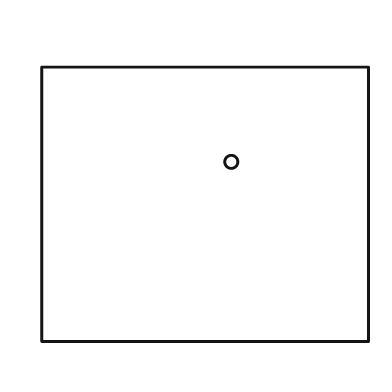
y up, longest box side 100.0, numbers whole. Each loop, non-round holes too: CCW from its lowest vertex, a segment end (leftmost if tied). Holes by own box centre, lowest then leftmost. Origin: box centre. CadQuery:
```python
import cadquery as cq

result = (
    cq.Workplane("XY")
    .moveTo(-50.0, -42.0)
    .lineTo(50.0, -42.0)
    .lineTo(50.0, 42.0)
    .lineTo(-50.0, 42.0)
    .close()
    .moveTo(8.0, 13.0)
    .circle(2.0)
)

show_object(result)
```